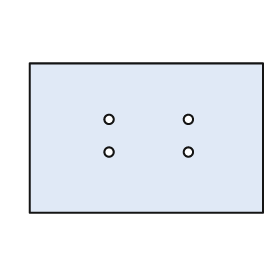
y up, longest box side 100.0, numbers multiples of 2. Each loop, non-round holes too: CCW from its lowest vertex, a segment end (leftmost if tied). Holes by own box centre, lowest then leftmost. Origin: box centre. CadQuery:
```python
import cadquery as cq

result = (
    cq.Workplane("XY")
    .moveTo(-50.0, -32.0)
    .lineTo(50.0, -32.0)
    .lineTo(50.0, 32.0)
    .lineTo(-50.0, 32.0)
    .close()
    .moveTo(-16.0, -6.0)
    .circle(2.0)
    .moveTo(18.0, -6.0)
    .circle(2.0)
    .moveTo(-16.0, 8.0)
    .circle(2.0)
    .moveTo(18.0, 8.0)
    .circle(2.0)
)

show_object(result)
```